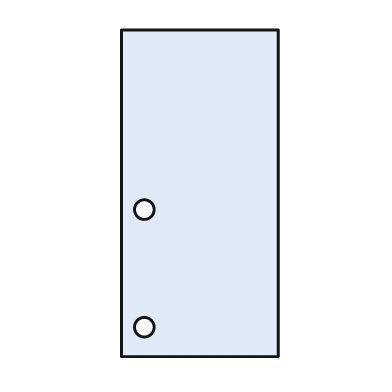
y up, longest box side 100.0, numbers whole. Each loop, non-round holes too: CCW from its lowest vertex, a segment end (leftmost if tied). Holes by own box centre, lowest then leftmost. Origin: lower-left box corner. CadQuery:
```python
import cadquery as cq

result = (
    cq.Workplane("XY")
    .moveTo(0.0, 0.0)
    .lineTo(48.0, 0.0)
    .lineTo(48.0, 100.0)
    .lineTo(0.0, 100.0)
    .close()
    .moveTo(7.0, 9.0)
    .circle(3.0)
    .moveTo(7.0, 45.0)
    .circle(3.0)
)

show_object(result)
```